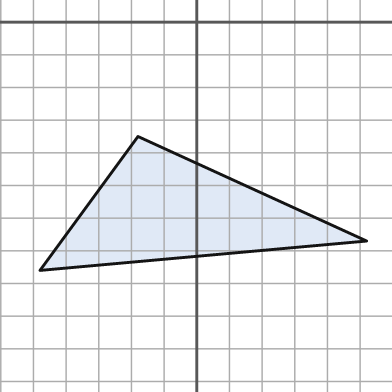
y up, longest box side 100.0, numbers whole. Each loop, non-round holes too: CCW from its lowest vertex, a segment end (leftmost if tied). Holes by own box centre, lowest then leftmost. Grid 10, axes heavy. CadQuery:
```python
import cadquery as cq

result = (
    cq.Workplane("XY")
    .moveTo(-48.0, -76.0)
    .lineTo(52.0, -67.0)
    .lineTo(-18.0, -35.0)
    .close()
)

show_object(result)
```